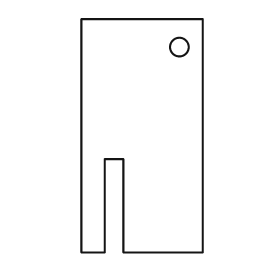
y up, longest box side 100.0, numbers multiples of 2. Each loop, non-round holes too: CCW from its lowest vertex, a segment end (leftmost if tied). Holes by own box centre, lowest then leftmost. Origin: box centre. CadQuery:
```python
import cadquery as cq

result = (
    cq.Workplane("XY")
    .moveTo(-26.0, -50.0)
    .lineTo(-16.0, -50.0)
    .lineTo(-16.0, -10.0)
    .lineTo(-8.0, -10.0)
    .lineTo(-8.0, -50.0)
    .lineTo(26.0, -50.0)
    .lineTo(26.0, 50.0)
    .lineTo(-26.0, 50.0)
    .close()
    .moveTo(16.0, 38.0)
    .circle(4.0)
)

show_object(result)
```